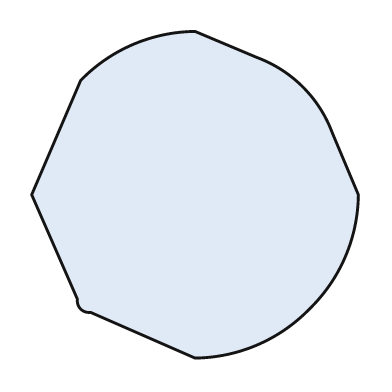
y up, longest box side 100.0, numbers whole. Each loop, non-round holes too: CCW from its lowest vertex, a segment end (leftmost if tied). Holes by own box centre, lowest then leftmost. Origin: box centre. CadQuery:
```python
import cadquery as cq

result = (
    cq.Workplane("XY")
    .moveTo(0.0, -50.0)
    .threePointArc((19.0, -46.0), (35.0, -35.0))
    .threePointArc((46.0, -19.0), (50.0, 0.0))
    .lineTo(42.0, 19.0)
    .threePointArc((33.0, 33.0), (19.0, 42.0))
    .lineTo(0.0, 50.0)
    .threePointArc((-19.0, 46.0), (-35.0, 35.0))
    .lineTo(-50.0, 0.0)
    .lineTo(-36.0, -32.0)
    .threePointArc((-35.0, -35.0), (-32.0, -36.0))
    .close()
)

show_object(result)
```